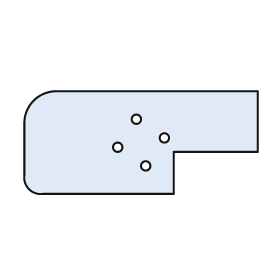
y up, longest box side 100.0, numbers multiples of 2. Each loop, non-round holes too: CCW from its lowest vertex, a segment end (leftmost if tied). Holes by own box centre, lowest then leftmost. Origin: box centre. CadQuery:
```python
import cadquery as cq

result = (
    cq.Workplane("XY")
    .moveTo(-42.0, -22.0)
    .lineTo(14.0, -22.0)
    .lineTo(14.0, -4.0)
    .lineTo(50.0, -4.0)
    .lineTo(50.0, 22.0)
    .lineTo(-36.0, 22.0)
    .threePointArc((-46.0, 18.0), (-50.0, 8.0))
    .lineTo(-50.0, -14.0)
    .threePointArc((-48.0, -20.0), (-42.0, -22.0))
    .close()
    .moveTo(2.0, -10.0)
    .circle(2.0)
    .moveTo(-10.0, -2.0)
    .circle(2.0)
    .moveTo(10.0, 2.0)
    .circle(2.0)
    .moveTo(-2.0, 10.0)
    .circle(2.0)
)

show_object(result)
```